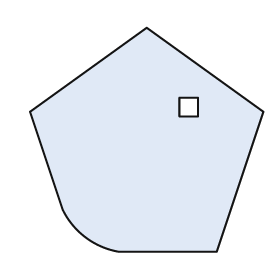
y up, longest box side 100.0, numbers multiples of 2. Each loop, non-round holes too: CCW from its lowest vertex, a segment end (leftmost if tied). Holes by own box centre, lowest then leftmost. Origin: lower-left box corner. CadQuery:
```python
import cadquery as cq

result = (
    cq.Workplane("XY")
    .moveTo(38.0, 0.0)
    .lineTo(80.0, 0.0)
    .lineTo(100.0, 60.0)
    .lineTo(50.0, 96.0)
    .lineTo(0.0, 60.0)
    .lineTo(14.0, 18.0)
    .threePointArc((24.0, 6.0), (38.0, 0.0))
    .close()
    .moveTo(64.0, 58.0)
    .lineTo(72.0, 58.0)
    .lineTo(72.0, 66.0)
    .lineTo(64.0, 66.0)
    .close()
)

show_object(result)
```